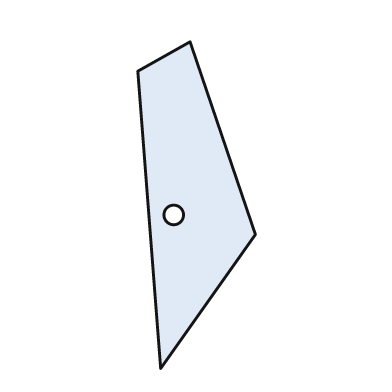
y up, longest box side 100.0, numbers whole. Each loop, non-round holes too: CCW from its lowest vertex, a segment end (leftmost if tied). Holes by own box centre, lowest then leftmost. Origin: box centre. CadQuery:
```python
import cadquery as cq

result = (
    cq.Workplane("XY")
    .moveTo(-11.0, -50.0)
    .lineTo(18.0, -9.0)
    .lineTo(-2.0, 50.0)
    .lineTo(-18.0, 41.0)
    .close()
    .moveTo(-7.0, -3.0)
    .circle(3.0)
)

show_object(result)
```